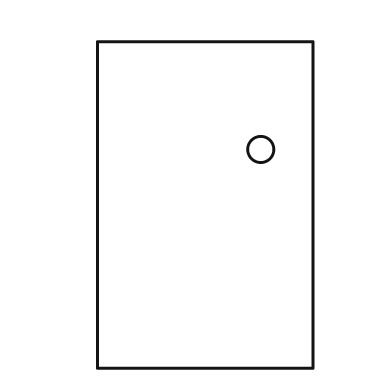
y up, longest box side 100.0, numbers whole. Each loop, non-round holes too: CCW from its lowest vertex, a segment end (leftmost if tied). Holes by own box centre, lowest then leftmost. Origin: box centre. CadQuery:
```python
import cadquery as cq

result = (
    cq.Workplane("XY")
    .moveTo(-33.0, -50.0)
    .lineTo(33.0, -50.0)
    .lineTo(33.0, 50.0)
    .lineTo(-33.0, 50.0)
    .close()
    .moveTo(17.0, 17.0)
    .circle(4.0)
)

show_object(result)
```